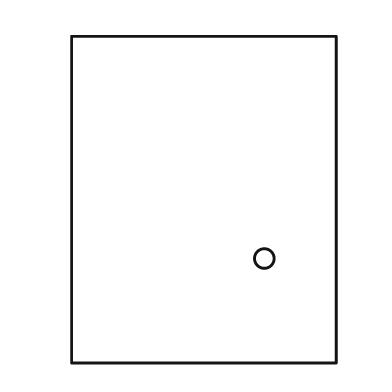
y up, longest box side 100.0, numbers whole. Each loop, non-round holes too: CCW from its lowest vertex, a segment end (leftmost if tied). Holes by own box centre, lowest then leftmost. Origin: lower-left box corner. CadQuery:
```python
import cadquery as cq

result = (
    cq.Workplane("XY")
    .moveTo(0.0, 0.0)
    .lineTo(81.0, 0.0)
    .lineTo(81.0, 100.0)
    .lineTo(0.0, 100.0)
    .close()
    .moveTo(59.0, 32.0)
    .circle(3.0)
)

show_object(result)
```